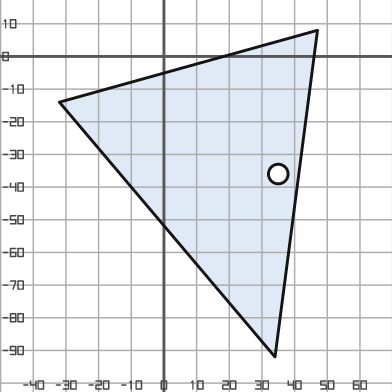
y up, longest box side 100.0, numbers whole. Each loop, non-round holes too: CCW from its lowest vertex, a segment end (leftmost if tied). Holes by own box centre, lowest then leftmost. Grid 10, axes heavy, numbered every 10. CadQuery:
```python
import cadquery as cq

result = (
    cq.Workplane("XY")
    .moveTo(34.0, -92.0)
    .lineTo(47.0, 8.0)
    .lineTo(-32.0, -14.0)
    .close()
    .moveTo(35.0, -36.0)
    .circle(3.0)
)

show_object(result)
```